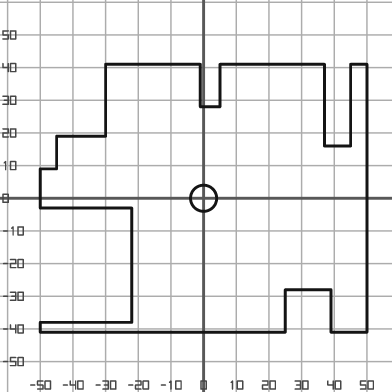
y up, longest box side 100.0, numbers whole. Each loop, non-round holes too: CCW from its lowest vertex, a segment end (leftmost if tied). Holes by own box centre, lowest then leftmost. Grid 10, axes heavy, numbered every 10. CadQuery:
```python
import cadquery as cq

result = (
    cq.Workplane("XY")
    .moveTo(-50.0, -41.0)
    .lineTo(25.0, -41.0)
    .lineTo(25.0, -28.0)
    .lineTo(39.0, -28.0)
    .lineTo(39.0, -41.0)
    .lineTo(50.0, -41.0)
    .lineTo(50.0, 41.0)
    .lineTo(45.0, 41.0)
    .lineTo(45.0, 16.0)
    .lineTo(37.0, 16.0)
    .lineTo(37.0, 41.0)
    .lineTo(5.0, 41.0)
    .lineTo(5.0, 28.0)
    .lineTo(-1.0, 28.0)
    .lineTo(-1.0, 41.0)
    .lineTo(-30.0, 41.0)
    .lineTo(-30.0, 19.0)
    .lineTo(-45.0, 19.0)
    .lineTo(-45.0, 9.0)
    .lineTo(-50.0, 9.0)
    .lineTo(-50.0, -3.0)
    .lineTo(-22.0, -3.0)
    .lineTo(-22.0, -38.0)
    .lineTo(-50.0, -38.0)
    .close()
    .moveTo(0.0, 0.0)
    .circle(4.0)
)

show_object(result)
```